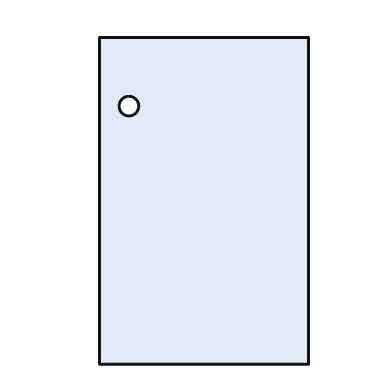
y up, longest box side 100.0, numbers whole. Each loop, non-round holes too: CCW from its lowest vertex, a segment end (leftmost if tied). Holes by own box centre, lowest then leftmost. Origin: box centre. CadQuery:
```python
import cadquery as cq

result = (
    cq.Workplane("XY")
    .moveTo(-32.0, -50.0)
    .lineTo(32.0, -50.0)
    .lineTo(32.0, 50.0)
    .lineTo(-32.0, 50.0)
    .close()
    .moveTo(-23.0, 29.0)
    .circle(3.0)
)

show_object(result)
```